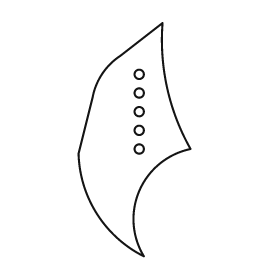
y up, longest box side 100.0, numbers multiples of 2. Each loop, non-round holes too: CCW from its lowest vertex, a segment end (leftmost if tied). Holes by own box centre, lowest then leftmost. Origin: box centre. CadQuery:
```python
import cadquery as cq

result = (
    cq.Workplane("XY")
    .moveTo(4.0, -50.0)
    .threePointArc((2.0, -22.0), (24.0, -4.0))
    .threePointArc((14.0, 22.0), (12.0, 50.0))
    .lineTo(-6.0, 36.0)
    .threePointArc((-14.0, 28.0), (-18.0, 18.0))
    .lineTo(-24.0, -6.0)
    .threePointArc((-16.0, -32.0), (4.0, -50.0))
    .close()
    .moveTo(2.0, -4.0)
    .circle(2.0)
    .moveTo(2.0, 4.0)
    .circle(2.0)
    .moveTo(2.0, 12.0)
    .circle(2.0)
    .moveTo(2.0, 20.0)
    .circle(2.0)
    .moveTo(2.0, 28.0)
    .circle(2.0)
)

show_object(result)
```